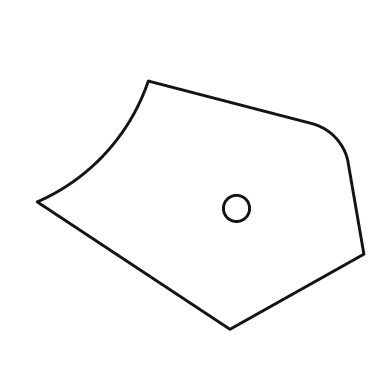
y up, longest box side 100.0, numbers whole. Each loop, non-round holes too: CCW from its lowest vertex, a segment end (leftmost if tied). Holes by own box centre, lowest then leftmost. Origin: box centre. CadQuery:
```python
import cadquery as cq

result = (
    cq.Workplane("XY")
    .moveTo(9.0, -38.0)
    .lineTo(50.0, -15.0)
    .lineTo(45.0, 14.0)
    .threePointArc((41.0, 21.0), (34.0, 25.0))
    .lineTo(-16.0, 38.0)
    .threePointArc((-29.0, 16.0), (-50.0, 1.0))
    .close()
    .moveTo(11.0, -1.0)
    .circle(4.0)
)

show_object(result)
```